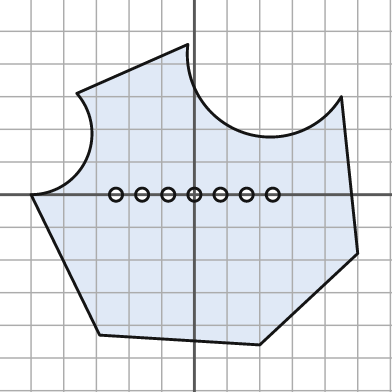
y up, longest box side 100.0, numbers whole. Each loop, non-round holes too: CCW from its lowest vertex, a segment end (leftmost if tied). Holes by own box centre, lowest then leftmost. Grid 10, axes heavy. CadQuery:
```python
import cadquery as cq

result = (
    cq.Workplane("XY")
    .moveTo(20.0, -46.0)
    .lineTo(50.0, -18.0)
    .lineTo(45.0, 30.0)
    .threePointArc((15.0, 19.0), (-2.0, 46.0))
    .lineTo(-36.0, 31.0)
    .threePointArc((-33.0, 11.0), (-50.0, 0.0))
    .lineTo(-29.0, -43.0)
    .close()
    .moveTo(-24.0, 0.0)
    .circle(2.0)
    .moveTo(-16.0, 0.0)
    .circle(2.0)
    .moveTo(-8.0, 0.0)
    .circle(2.0)
    .moveTo(0.0, 0.0)
    .circle(2.0)
    .moveTo(8.0, 0.0)
    .circle(2.0)
    .moveTo(16.0, 0.0)
    .circle(2.0)
    .moveTo(24.0, 0.0)
    .circle(2.0)
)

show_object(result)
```